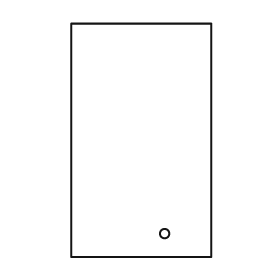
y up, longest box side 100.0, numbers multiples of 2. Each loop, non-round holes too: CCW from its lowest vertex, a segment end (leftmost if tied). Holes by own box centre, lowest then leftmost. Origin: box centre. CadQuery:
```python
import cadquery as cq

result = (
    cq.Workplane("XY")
    .moveTo(-30.0, -50.0)
    .lineTo(30.0, -50.0)
    .lineTo(30.0, 50.0)
    .lineTo(-30.0, 50.0)
    .close()
    .moveTo(10.0, -40.0)
    .circle(2.0)
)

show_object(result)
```